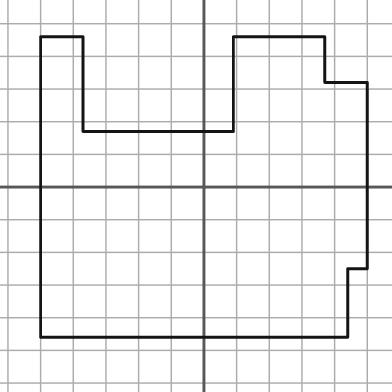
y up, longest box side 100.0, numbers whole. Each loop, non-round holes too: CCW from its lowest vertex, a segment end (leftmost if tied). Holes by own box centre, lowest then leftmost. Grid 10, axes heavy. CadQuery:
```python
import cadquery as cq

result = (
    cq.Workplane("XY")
    .moveTo(-50.0, -46.0)
    .lineTo(44.0, -46.0)
    .lineTo(44.0, -25.0)
    .lineTo(50.0, -25.0)
    .lineTo(50.0, 32.0)
    .lineTo(37.0, 32.0)
    .lineTo(37.0, 46.0)
    .lineTo(9.0, 46.0)
    .lineTo(9.0, 17.0)
    .lineTo(-37.0, 17.0)
    .lineTo(-37.0, 46.0)
    .lineTo(-50.0, 46.0)
    .close()
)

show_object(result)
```